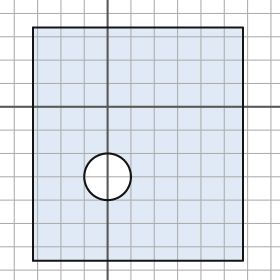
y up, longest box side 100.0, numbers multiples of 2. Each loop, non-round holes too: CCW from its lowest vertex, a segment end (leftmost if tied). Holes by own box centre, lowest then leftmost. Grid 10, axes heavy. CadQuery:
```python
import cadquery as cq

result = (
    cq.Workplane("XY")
    .moveTo(-32.0, -66.0)
    .lineTo(58.0, -66.0)
    .lineTo(58.0, 34.0)
    .lineTo(-32.0, 34.0)
    .close()
    .moveTo(0.0, -30.0)
    .circle(10.0)
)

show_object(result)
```